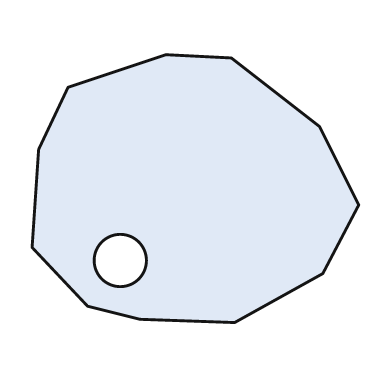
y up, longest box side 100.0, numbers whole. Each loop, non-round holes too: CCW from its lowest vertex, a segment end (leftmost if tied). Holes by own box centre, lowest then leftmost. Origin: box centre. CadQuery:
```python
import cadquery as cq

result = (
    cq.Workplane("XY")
    .moveTo(12.0, -41.0)
    .lineTo(39.0, -26.0)
    .lineTo(50.0, -5.0)
    .lineTo(38.0, 19.0)
    .lineTo(11.0, 40.0)
    .lineTo(-9.0, 41.0)
    .lineTo(-39.0, 31.0)
    .lineTo(-48.0, 12.0)
    .lineTo(-50.0, -18.0)
    .lineTo(-33.0, -36.0)
    .lineTo(-17.0, -40.0)
    .close()
    .moveTo(-23.0, -22.0)
    .circle(8.0)
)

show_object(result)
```